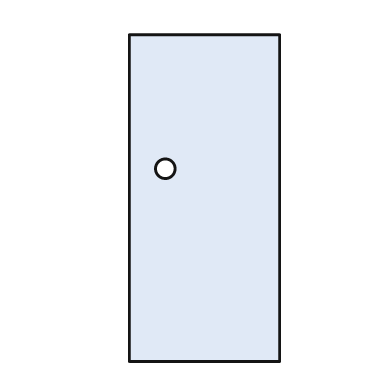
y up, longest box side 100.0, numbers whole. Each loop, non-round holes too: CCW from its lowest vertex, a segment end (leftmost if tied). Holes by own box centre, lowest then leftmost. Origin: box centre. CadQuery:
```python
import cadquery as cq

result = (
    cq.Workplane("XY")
    .moveTo(-23.0, -50.0)
    .lineTo(23.0, -50.0)
    .lineTo(23.0, 50.0)
    .lineTo(-23.0, 50.0)
    .close()
    .moveTo(-12.0, 9.0)
    .circle(3.0)
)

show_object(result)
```